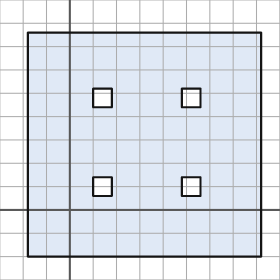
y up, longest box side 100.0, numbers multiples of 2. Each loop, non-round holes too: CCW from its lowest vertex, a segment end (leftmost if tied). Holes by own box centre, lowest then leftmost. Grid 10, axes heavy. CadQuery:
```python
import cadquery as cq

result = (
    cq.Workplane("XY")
    .moveTo(-18.0, -20.0)
    .lineTo(82.0, -20.0)
    .lineTo(82.0, 76.0)
    .lineTo(-18.0, 76.0)
    .close()
    .moveTo(10.0, 6.0)
    .lineTo(18.0, 6.0)
    .lineTo(18.0, 14.0)
    .lineTo(10.0, 14.0)
    .close()
    .moveTo(48.0, 6.0)
    .lineTo(56.0, 6.0)
    .lineTo(56.0, 14.0)
    .lineTo(48.0, 14.0)
    .close()
    .moveTo(10.0, 44.0)
    .lineTo(18.0, 44.0)
    .lineTo(18.0, 52.0)
    .lineTo(10.0, 52.0)
    .close()
    .moveTo(48.0, 44.0)
    .lineTo(56.0, 44.0)
    .lineTo(56.0, 52.0)
    .lineTo(48.0, 52.0)
    .close()
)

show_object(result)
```